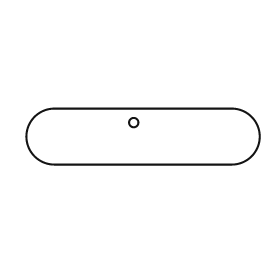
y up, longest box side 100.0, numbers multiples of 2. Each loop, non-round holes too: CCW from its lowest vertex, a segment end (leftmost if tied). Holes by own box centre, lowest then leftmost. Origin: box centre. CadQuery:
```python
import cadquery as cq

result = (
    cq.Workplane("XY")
    .moveTo(-38.0, -12.0)
    .lineTo(38.0, -12.0)
    .threePointArc((50.0, 0.0), (38.0, 12.0))
    .lineTo(-38.0, 12.0)
    .threePointArc((-50.0, 0.0), (-38.0, -12.0))
    .close()
    .moveTo(-4.0, 6.0)
    .circle(2.0)
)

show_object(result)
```